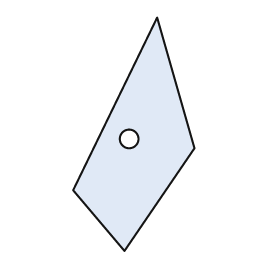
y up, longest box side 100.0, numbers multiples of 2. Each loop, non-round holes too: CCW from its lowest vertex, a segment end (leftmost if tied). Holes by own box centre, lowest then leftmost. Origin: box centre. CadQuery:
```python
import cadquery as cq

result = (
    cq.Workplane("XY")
    .moveTo(-4.0, -50.0)
    .lineTo(26.0, -6.0)
    .lineTo(10.0, 50.0)
    .lineTo(-26.0, -24.0)
    .close()
    .moveTo(-2.0, -2.0)
    .circle(4.0)
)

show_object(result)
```